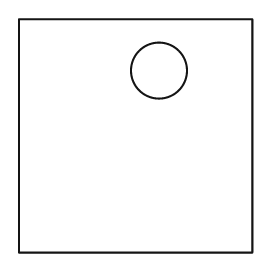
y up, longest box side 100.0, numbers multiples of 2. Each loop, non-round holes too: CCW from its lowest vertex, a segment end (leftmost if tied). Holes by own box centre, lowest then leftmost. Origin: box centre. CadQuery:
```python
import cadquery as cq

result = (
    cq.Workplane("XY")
    .moveTo(-50.0, -50.0)
    .lineTo(50.0, -50.0)
    .lineTo(50.0, 50.0)
    .lineTo(-50.0, 50.0)
    .close()
    .moveTo(10.0, 28.0)
    .circle(12.0)
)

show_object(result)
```